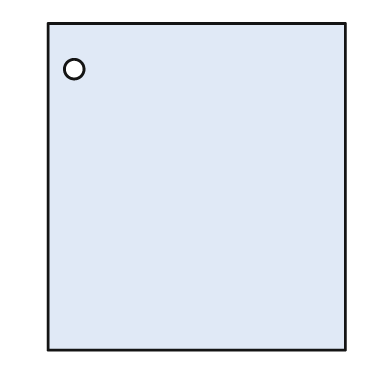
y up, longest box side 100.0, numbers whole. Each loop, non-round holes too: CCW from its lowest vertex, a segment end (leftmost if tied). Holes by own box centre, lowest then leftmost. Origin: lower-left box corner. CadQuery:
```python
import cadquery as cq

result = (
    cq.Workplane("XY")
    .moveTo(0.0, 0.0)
    .lineTo(91.0, 0.0)
    .lineTo(91.0, 100.0)
    .lineTo(0.0, 100.0)
    .close()
    .moveTo(8.0, 86.0)
    .circle(3.0)
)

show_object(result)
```